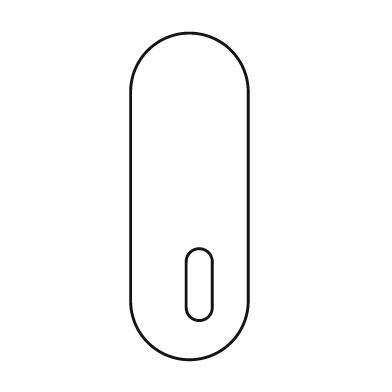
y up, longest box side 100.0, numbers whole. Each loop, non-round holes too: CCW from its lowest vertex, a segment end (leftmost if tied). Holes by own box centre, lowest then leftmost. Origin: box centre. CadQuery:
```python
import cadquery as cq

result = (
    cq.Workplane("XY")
    .moveTo(-18.0, -32.0)
    .threePointArc((0.0, -50.0), (18.0, -32.0))
    .lineTo(18.0, 32.0)
    .threePointArc((0.0, 50.0), (-18.0, 32.0))
    .close()
    .moveTo(-1.0, -34.0)
    .threePointArc((3.0, -38.0), (7.0, -34.0))
    .lineTo(7.0, -20.0)
    .threePointArc((3.0, -16.0), (-1.0, -20.0))
    .close()
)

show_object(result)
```